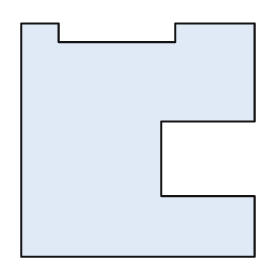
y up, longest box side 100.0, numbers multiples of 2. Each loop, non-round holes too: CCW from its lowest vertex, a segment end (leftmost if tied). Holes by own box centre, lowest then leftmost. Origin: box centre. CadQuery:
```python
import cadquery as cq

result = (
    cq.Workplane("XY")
    .moveTo(-50.0, -50.0)
    .lineTo(50.0, -50.0)
    .lineTo(50.0, -24.0)
    .lineTo(10.0, -24.0)
    .lineTo(10.0, 8.0)
    .lineTo(50.0, 8.0)
    .lineTo(50.0, 50.0)
    .lineTo(16.0, 50.0)
    .lineTo(16.0, 42.0)
    .lineTo(-34.0, 42.0)
    .lineTo(-34.0, 50.0)
    .lineTo(-50.0, 50.0)
    .close()
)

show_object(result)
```